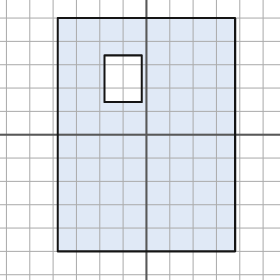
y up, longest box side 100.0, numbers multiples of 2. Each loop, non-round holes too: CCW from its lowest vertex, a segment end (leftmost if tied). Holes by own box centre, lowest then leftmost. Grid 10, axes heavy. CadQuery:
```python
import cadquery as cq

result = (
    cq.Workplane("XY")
    .moveTo(-38.0, -50.0)
    .lineTo(38.0, -50.0)
    .lineTo(38.0, 50.0)
    .lineTo(-38.0, 50.0)
    .close()
    .moveTo(-18.0, 14.0)
    .lineTo(-2.0, 14.0)
    .lineTo(-2.0, 34.0)
    .lineTo(-18.0, 34.0)
    .close()
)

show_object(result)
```